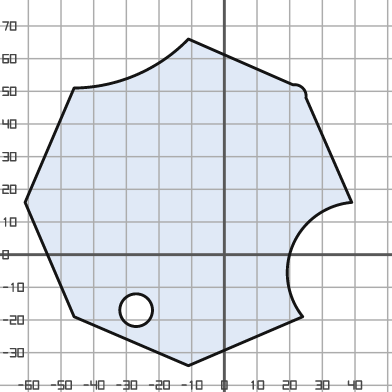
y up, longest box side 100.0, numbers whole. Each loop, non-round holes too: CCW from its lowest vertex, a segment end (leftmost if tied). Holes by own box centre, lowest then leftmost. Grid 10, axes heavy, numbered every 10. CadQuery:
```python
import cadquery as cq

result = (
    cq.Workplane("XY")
    .moveTo(-11.0, -34.0)
    .lineTo(24.0, -19.0)
    .threePointArc((21.0, 3.0), (39.0, 16.0))
    .lineTo(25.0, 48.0)
    .threePointArc((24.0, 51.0), (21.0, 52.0))
    .lineTo(-11.0, 66.0)
    .threePointArc((-27.0, 55.0), (-46.0, 51.0))
    .lineTo(-61.0, 16.0)
    .lineTo(-46.0, -19.0)
    .close()
    .moveTo(-27.0, -17.0)
    .circle(5.0)
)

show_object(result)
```